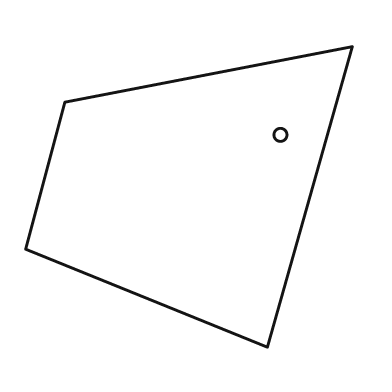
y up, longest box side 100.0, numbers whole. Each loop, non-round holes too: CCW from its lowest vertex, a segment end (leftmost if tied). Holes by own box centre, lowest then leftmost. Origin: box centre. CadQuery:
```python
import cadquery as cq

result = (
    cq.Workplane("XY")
    .moveTo(24.0, -46.0)
    .lineTo(50.0, 46.0)
    .lineTo(-38.0, 29.0)
    .lineTo(-50.0, -16.0)
    .close()
    .moveTo(28.0, 19.0)
    .circle(2.0)
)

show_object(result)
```